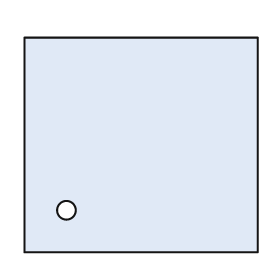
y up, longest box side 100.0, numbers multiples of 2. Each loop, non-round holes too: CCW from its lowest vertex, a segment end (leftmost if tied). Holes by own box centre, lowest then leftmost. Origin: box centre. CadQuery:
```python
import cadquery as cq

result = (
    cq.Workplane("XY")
    .moveTo(-50.0, -46.0)
    .lineTo(50.0, -46.0)
    .lineTo(50.0, 46.0)
    .lineTo(-50.0, 46.0)
    .close()
    .moveTo(-32.0, -28.0)
    .circle(4.0)
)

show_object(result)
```